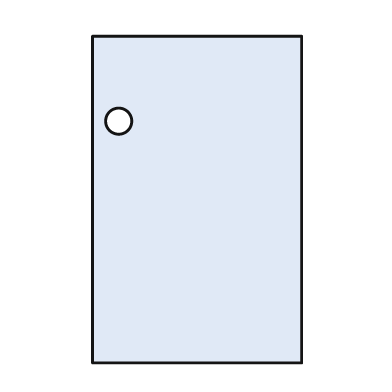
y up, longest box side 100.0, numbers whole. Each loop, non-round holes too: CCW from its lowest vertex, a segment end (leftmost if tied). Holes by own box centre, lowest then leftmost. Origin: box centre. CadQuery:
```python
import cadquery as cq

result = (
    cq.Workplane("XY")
    .moveTo(-32.0, -50.0)
    .lineTo(32.0, -50.0)
    .lineTo(32.0, 50.0)
    .lineTo(-32.0, 50.0)
    .close()
    .moveTo(-24.0, 24.0)
    .circle(4.0)
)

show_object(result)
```